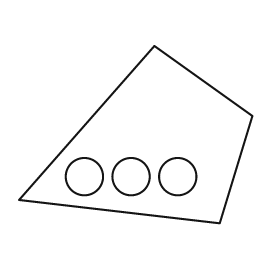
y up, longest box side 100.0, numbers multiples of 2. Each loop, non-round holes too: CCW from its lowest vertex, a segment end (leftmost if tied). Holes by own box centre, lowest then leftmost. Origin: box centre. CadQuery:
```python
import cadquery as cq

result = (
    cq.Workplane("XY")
    .moveTo(36.0, -38.0)
    .lineTo(50.0, 8.0)
    .lineTo(8.0, 38.0)
    .lineTo(-50.0, -28.0)
    .close()
    .moveTo(-22.0, -18.0)
    .circle(8.0)
    .moveTo(-2.0, -18.0)
    .circle(8.0)
    .moveTo(18.0, -18.0)
    .circle(8.0)
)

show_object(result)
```